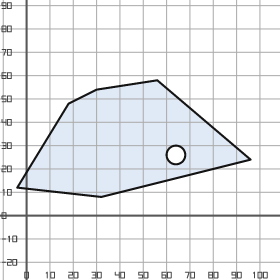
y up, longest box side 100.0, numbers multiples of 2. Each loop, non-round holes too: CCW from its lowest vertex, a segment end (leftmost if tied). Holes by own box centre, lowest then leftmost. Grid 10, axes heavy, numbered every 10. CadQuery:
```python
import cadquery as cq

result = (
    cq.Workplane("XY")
    .moveTo(32.0, 8.0)
    .lineTo(96.0, 24.0)
    .lineTo(56.0, 58.0)
    .lineTo(30.0, 54.0)
    .lineTo(18.0, 48.0)
    .lineTo(-4.0, 12.0)
    .close()
    .moveTo(64.0, 26.0)
    .circle(4.0)
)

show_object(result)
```